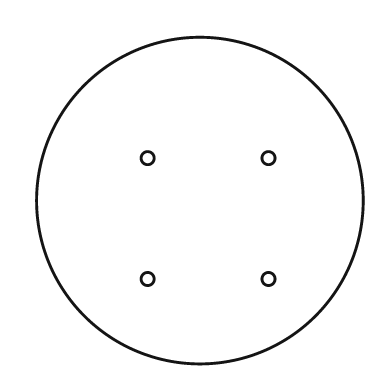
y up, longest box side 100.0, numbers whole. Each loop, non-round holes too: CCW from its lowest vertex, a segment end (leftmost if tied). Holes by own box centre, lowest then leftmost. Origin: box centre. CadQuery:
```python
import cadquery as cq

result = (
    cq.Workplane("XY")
    .moveTo(0.0, 0.0)
    .circle(50.0)
    .moveTo(-16.0, -24.0)
    .circle(2.0)
    .moveTo(21.0, -24.0)
    .circle(2.0)
    .moveTo(-16.0, 13.0)
    .circle(2.0)
    .moveTo(21.0, 13.0)
    .circle(2.0)
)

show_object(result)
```